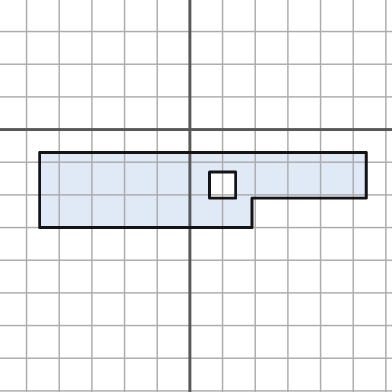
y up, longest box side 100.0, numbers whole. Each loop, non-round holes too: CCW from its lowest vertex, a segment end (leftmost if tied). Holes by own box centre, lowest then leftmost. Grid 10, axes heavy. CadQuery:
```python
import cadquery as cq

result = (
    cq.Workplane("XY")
    .moveTo(-46.0, -30.0)
    .lineTo(19.0, -30.0)
    .lineTo(19.0, -21.0)
    .lineTo(54.0, -21.0)
    .lineTo(54.0, -7.0)
    .lineTo(-46.0, -7.0)
    .close()
    .moveTo(6.0, -21.0)
    .lineTo(14.0, -21.0)
    .lineTo(14.0, -13.0)
    .lineTo(6.0, -13.0)
    .close()
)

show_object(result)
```